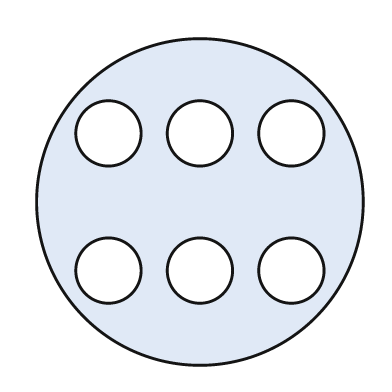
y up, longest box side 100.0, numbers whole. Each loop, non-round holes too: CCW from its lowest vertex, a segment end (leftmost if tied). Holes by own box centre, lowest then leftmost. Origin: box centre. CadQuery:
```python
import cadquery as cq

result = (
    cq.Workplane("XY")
    .moveTo(0.0, 0.0)
    .circle(50.0)
    .moveTo(-28.0, -21.0)
    .circle(10.0)
    .moveTo(0.0, -21.0)
    .circle(10.0)
    .moveTo(28.0, -21.0)
    .circle(10.0)
    .moveTo(-28.0, 21.0)
    .circle(10.0)
    .moveTo(0.0, 21.0)
    .circle(10.0)
    .moveTo(28.0, 21.0)
    .circle(10.0)
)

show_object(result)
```